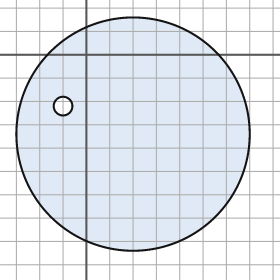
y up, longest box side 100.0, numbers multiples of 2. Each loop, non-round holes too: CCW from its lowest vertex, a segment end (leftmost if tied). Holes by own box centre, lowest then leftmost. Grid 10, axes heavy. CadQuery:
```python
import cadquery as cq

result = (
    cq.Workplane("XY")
    .moveTo(20.0, -34.0)
    .circle(50.0)
    .moveTo(-10.0, -22.0)
    .circle(4.0)
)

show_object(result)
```